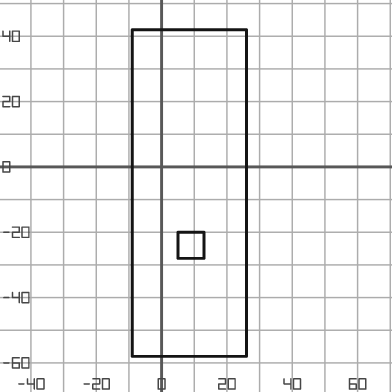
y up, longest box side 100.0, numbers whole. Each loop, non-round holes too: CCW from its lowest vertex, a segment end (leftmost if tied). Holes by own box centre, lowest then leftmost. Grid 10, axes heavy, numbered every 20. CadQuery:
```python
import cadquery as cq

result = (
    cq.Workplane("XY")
    .moveTo(-9.0, -58.0)
    .lineTo(26.0, -58.0)
    .lineTo(26.0, 42.0)
    .lineTo(-9.0, 42.0)
    .close()
    .moveTo(5.0, -28.0)
    .lineTo(13.0, -28.0)
    .lineTo(13.0, -20.0)
    .lineTo(5.0, -20.0)
    .close()
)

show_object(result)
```